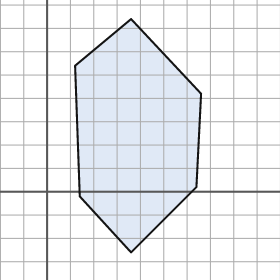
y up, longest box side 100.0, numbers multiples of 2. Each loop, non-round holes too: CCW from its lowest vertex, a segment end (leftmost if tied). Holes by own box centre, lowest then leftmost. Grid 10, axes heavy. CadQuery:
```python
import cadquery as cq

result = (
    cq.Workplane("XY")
    .moveTo(36.0, -26.0)
    .lineTo(64.0, 2.0)
    .lineTo(66.0, 42.0)
    .lineTo(36.0, 74.0)
    .lineTo(12.0, 54.0)
    .lineTo(14.0, -2.0)
    .close()
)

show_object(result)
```